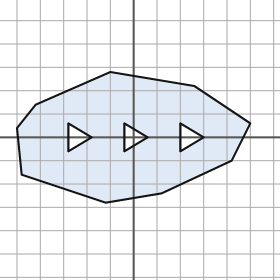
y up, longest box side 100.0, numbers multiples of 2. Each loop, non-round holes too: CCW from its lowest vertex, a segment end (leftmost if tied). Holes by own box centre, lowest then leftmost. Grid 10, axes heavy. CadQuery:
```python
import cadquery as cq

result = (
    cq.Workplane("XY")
    .moveTo(-12.0, -28.0)
    .lineTo(12.0, -24.0)
    .lineTo(42.0, -10.0)
    .lineTo(50.0, 6.0)
    .lineTo(26.0, 22.0)
    .lineTo(-10.0, 28.0)
    .lineTo(-42.0, 14.0)
    .lineTo(-50.0, 4.0)
    .lineTo(-48.0, -16.0)
    .close()
    .moveTo(-28.0, -6.0)
    .lineTo(-18.0, 0.0)
    .lineTo(-28.0, 6.0)
    .close()
    .moveTo(-4.0, -6.0)
    .lineTo(6.0, 0.0)
    .lineTo(-4.0, 6.0)
    .close()
    .moveTo(20.0, -6.0)
    .lineTo(30.0, 0.0)
    .lineTo(20.0, 6.0)
    .close()
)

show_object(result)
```